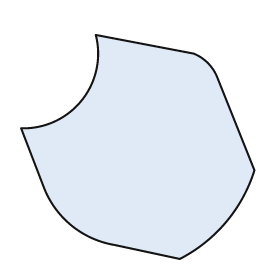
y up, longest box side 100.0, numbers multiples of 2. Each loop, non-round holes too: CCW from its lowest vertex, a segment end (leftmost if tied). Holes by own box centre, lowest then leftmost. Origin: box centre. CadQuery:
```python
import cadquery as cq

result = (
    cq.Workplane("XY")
    .moveTo(18.0, -48.0)
    .threePointArc((38.0, -32.0), (50.0, -10.0))
    .lineTo(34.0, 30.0)
    .threePointArc((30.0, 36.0), (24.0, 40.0))
    .lineTo(-18.0, 48.0)
    .threePointArc((-24.0, 20.0), (-50.0, 8.0))
    .lineTo(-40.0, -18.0)
    .threePointArc((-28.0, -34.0), (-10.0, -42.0))
    .close()
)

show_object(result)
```